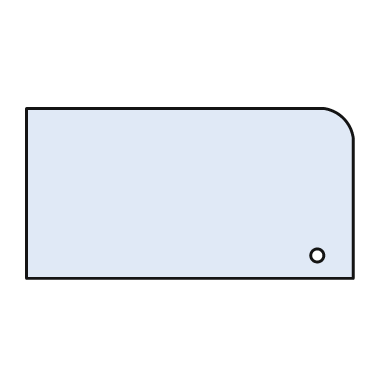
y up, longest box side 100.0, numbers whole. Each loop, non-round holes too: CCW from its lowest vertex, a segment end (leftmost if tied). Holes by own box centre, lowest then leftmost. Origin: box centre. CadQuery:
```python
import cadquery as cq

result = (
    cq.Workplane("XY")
    .moveTo(-50.0, -26.0)
    .lineTo(50.0, -26.0)
    .lineTo(50.0, 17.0)
    .threePointArc((47.0, 23.0), (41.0, 26.0))
    .lineTo(-50.0, 26.0)
    .close()
    .moveTo(39.0, -19.0)
    .circle(2.0)
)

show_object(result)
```